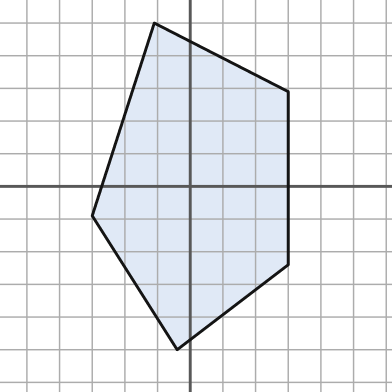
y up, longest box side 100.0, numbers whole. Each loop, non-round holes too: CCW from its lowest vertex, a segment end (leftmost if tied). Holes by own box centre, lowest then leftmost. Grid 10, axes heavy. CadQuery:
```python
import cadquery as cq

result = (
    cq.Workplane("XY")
    .moveTo(-4.0, -50.0)
    .lineTo(30.0, -24.0)
    .lineTo(30.0, 29.0)
    .lineTo(-11.0, 50.0)
    .lineTo(-30.0, -9.0)
    .close()
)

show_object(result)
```